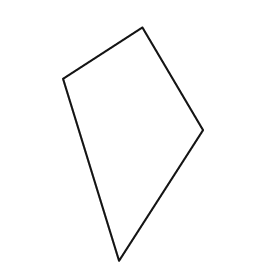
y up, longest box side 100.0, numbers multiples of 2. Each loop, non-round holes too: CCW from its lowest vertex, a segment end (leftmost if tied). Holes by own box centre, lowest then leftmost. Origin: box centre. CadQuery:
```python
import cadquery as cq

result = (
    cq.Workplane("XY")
    .moveTo(-6.0, -50.0)
    .lineTo(30.0, 6.0)
    .lineTo(4.0, 50.0)
    .lineTo(-30.0, 28.0)
    .close()
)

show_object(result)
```